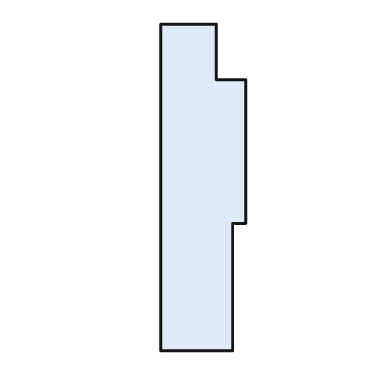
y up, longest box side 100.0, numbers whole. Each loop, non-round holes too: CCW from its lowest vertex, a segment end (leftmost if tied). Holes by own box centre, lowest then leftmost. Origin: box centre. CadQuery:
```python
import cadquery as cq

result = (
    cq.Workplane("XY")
    .moveTo(-13.0, -50.0)
    .lineTo(9.0, -50.0)
    .lineTo(9.0, -11.0)
    .lineTo(13.0, -11.0)
    .lineTo(13.0, 33.0)
    .lineTo(4.0, 33.0)
    .lineTo(4.0, 50.0)
    .lineTo(-13.0, 50.0)
    .close()
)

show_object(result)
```